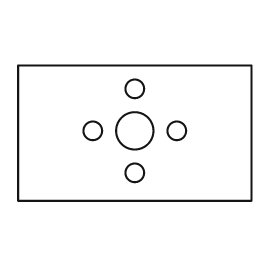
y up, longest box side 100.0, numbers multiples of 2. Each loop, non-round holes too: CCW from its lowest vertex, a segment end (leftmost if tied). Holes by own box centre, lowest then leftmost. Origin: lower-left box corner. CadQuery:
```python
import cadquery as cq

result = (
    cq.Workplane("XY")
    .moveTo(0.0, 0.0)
    .lineTo(100.0, 0.0)
    .lineTo(100.0, 58.0)
    .lineTo(0.0, 58.0)
    .close()
    .moveTo(50.0, 12.0)
    .circle(4.0)
    .moveTo(32.0, 30.0)
    .circle(4.0)
    .moveTo(50.0, 30.0)
    .circle(8.0)
    .moveTo(68.0, 30.0)
    .circle(4.0)
    .moveTo(50.0, 48.0)
    .circle(4.0)
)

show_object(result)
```